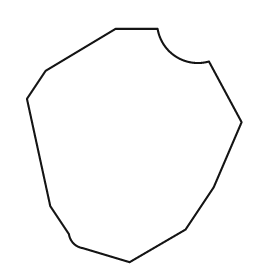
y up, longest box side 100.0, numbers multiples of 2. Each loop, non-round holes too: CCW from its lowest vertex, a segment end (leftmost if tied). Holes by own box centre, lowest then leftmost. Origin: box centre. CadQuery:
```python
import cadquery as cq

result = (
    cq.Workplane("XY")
    .moveTo(-2.0, -50.0)
    .lineTo(22.0, -36.0)
    .lineTo(34.0, -18.0)
    .lineTo(46.0, 10.0)
    .lineTo(32.0, 36.0)
    .threePointArc((18.0, 38.0), (10.0, 50.0))
    .lineTo(-8.0, 50.0)
    .lineTo(-38.0, 32.0)
    .lineTo(-46.0, 20.0)
    .lineTo(-36.0, -26.0)
    .lineTo(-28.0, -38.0)
    .threePointArc((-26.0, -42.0), (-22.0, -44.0))
    .close()
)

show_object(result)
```